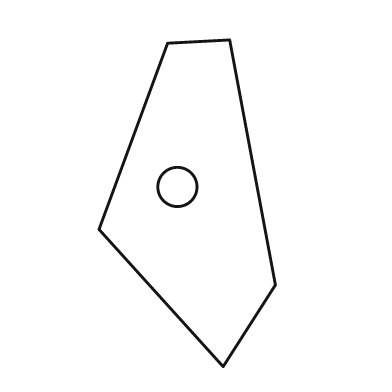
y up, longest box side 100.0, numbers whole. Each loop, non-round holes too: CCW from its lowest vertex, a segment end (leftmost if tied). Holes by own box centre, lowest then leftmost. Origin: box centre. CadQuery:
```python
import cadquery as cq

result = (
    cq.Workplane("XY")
    .moveTo(11.0, -50.0)
    .lineTo(27.0, -25.0)
    .lineTo(13.0, 50.0)
    .lineTo(-6.0, 49.0)
    .lineTo(-27.0, -8.0)
    .close()
    .moveTo(-3.0, 5.0)
    .circle(6.0)
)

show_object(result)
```